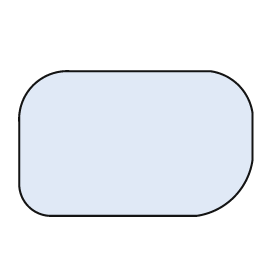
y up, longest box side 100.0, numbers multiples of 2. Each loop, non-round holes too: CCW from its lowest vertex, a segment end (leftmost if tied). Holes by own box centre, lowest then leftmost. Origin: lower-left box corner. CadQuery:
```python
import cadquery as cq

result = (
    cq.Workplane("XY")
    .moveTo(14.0, 0.0)
    .lineTo(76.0, 0.0)
    .threePointArc((92.0, 8.0), (100.0, 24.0))
    .lineTo(100.0, 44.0)
    .threePointArc((94.0, 56.0), (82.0, 62.0))
    .lineTo(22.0, 62.0)
    .threePointArc((6.0, 56.0), (0.0, 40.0))
    .lineTo(0.0, 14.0)
    .threePointArc((4.0, 4.0), (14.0, 0.0))
    .close()
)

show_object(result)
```